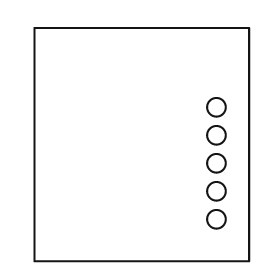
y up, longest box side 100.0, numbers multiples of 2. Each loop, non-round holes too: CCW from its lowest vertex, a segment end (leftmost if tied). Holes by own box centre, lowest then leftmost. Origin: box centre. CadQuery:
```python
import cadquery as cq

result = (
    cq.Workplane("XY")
    .moveTo(-46.0, -50.0)
    .lineTo(46.0, -50.0)
    .lineTo(46.0, 50.0)
    .lineTo(-46.0, 50.0)
    .close()
    .moveTo(32.0, -32.0)
    .circle(4.0)
    .moveTo(32.0, -20.0)
    .circle(4.0)
    .moveTo(32.0, -8.0)
    .circle(4.0)
    .moveTo(32.0, 4.0)
    .circle(4.0)
    .moveTo(32.0, 16.0)
    .circle(4.0)
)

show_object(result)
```